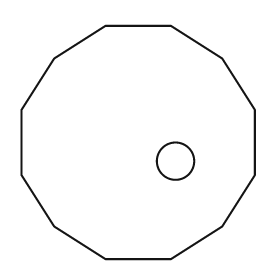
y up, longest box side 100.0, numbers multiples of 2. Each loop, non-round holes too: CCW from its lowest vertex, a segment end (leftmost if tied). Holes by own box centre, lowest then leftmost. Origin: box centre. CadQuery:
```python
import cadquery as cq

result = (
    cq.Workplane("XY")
    .moveTo(-14.0, -50.0)
    .lineTo(14.0, -50.0)
    .lineTo(36.0, -36.0)
    .lineTo(50.0, -14.0)
    .lineTo(50.0, 14.0)
    .lineTo(36.0, 36.0)
    .lineTo(14.0, 50.0)
    .lineTo(-14.0, 50.0)
    .lineTo(-36.0, 36.0)
    .lineTo(-50.0, 14.0)
    .lineTo(-50.0, -14.0)
    .lineTo(-36.0, -36.0)
    .close()
    .moveTo(16.0, -8.0)
    .circle(8.0)
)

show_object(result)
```